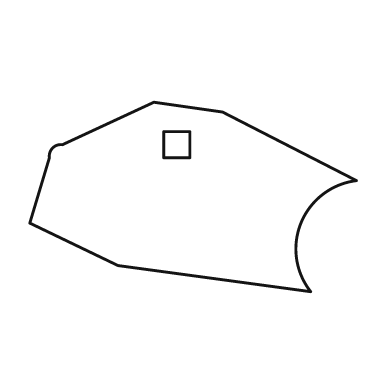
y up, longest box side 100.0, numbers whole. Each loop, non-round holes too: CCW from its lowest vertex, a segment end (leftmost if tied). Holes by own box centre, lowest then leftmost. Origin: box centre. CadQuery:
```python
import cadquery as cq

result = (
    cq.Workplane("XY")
    .moveTo(36.0, -29.0)
    .threePointArc((33.0, -8.0), (50.0, 5.0))
    .lineTo(9.0, 26.0)
    .lineTo(-12.0, 29.0)
    .lineTo(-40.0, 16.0)
    .threePointArc((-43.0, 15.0), (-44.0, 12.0))
    .lineTo(-50.0, -8.0)
    .lineTo(-23.0, -21.0)
    .close()
    .moveTo(-9.0, 12.0)
    .lineTo(-1.0, 12.0)
    .lineTo(-1.0, 20.0)
    .lineTo(-9.0, 20.0)
    .close()
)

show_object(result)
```